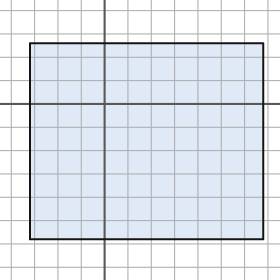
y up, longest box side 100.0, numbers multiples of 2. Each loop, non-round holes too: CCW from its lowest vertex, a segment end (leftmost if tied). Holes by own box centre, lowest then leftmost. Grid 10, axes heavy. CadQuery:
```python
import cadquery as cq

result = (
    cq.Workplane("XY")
    .moveTo(-32.0, -58.0)
    .lineTo(68.0, -58.0)
    .lineTo(68.0, 26.0)
    .lineTo(-32.0, 26.0)
    .close()
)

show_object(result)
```